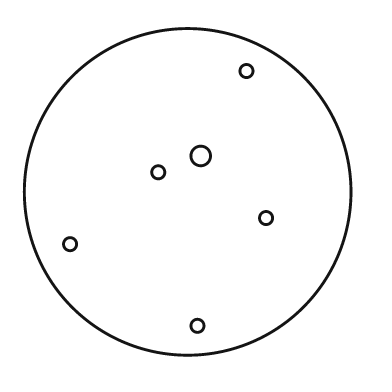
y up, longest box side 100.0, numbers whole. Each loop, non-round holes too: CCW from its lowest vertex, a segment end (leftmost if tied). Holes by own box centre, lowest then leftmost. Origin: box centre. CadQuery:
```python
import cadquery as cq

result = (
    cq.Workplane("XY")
    .moveTo(0.0, 0.0)
    .circle(50.0)
    .moveTo(3.0, -41.0)
    .circle(2.0)
    .moveTo(-36.0, -16.0)
    .circle(2.0)
    .moveTo(24.0, -8.0)
    .circle(2.0)
    .moveTo(-9.0, 6.0)
    .circle(2.0)
    .moveTo(4.0, 11.0)
    .circle(3.0)
    .moveTo(18.0, 37.0)
    .circle(2.0)
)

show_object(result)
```